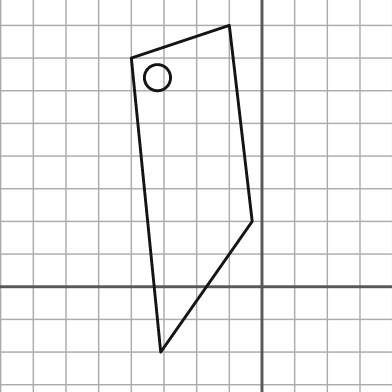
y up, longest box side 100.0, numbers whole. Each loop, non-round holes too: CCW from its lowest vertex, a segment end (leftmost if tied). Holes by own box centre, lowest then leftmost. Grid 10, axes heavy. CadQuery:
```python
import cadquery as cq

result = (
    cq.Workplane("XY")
    .moveTo(-31.0, -20.0)
    .lineTo(-3.0, 20.0)
    .lineTo(-10.0, 80.0)
    .lineTo(-40.0, 70.0)
    .close()
    .moveTo(-32.0, 64.0)
    .circle(4.0)
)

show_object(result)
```